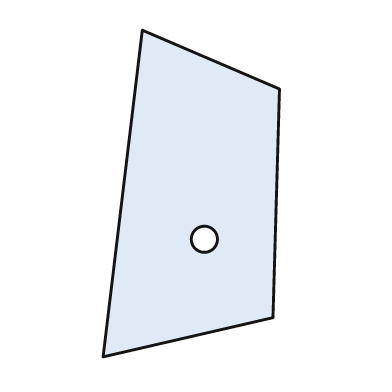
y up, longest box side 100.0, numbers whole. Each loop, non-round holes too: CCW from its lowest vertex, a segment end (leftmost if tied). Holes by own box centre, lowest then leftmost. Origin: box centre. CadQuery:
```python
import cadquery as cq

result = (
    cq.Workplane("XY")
    .moveTo(-27.0, -50.0)
    .lineTo(25.0, -38.0)
    .lineTo(27.0, 32.0)
    .lineTo(-15.0, 50.0)
    .close()
    .moveTo(4.0, -14.0)
    .circle(4.0)
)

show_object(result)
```